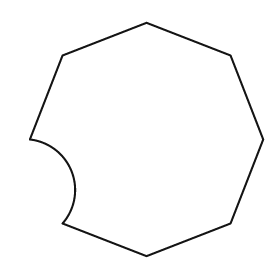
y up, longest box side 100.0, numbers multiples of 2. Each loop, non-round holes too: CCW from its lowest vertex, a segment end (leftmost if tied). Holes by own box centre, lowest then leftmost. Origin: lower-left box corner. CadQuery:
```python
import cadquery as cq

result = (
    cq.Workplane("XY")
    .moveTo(50.0, 0.0)
    .lineTo(86.0, 14.0)
    .lineTo(100.0, 50.0)
    .lineTo(86.0, 86.0)
    .lineTo(50.0, 100.0)
    .lineTo(14.0, 86.0)
    .lineTo(0.0, 50.0)
    .threePointArc((18.0, 36.0), (14.0, 14.0))
    .close()
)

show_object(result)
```